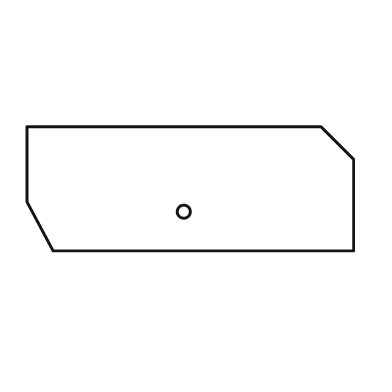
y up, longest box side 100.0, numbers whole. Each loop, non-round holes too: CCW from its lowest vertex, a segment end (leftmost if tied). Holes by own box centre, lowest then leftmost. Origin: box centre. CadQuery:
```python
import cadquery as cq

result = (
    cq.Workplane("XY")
    .moveTo(-42.0, -19.0)
    .lineTo(50.0, -19.0)
    .lineTo(50.0, 9.0)
    .lineTo(40.0, 19.0)
    .lineTo(-50.0, 19.0)
    .lineTo(-50.0, -4.0)
    .close()
    .moveTo(-2.0, -7.0)
    .circle(2.0)
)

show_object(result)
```